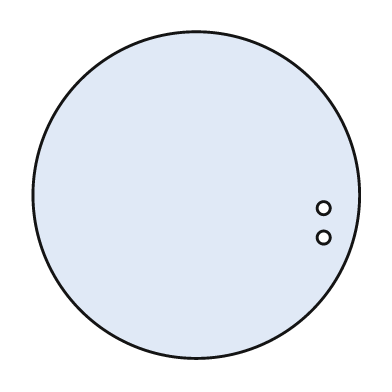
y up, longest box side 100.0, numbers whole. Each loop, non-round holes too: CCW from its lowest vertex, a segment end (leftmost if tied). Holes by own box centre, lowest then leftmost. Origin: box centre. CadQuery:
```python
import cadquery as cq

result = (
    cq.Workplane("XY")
    .moveTo(0.0, 0.0)
    .circle(50.0)
    .moveTo(39.0, -13.0)
    .circle(2.0)
    .moveTo(39.0, -4.0)
    .circle(2.0)
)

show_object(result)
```